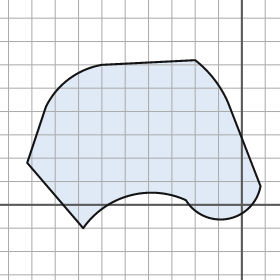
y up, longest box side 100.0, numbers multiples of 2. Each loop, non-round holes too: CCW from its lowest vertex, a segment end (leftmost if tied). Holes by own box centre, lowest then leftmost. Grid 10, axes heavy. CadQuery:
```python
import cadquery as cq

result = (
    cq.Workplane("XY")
    .moveTo(-68.0, -10.0)
    .threePointArc((-48.0, 4.0), (-24.0, 2.0))
    .threePointArc((-6.0, -6.0), (8.0, 8.0))
    .lineTo(-6.0, 44.0)
    .threePointArc((-12.0, 54.0), (-20.0, 62.0))
    .lineTo(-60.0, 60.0)
    .threePointArc((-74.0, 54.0), (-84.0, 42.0))
    .lineTo(-92.0, 18.0)
    .close()
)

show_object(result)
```